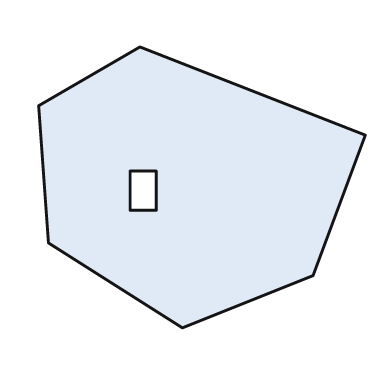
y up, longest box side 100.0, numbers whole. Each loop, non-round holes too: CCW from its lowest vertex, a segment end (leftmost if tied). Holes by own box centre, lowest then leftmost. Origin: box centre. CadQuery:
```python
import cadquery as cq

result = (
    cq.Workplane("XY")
    .moveTo(-6.0, -43.0)
    .lineTo(34.0, -27.0)
    .lineTo(50.0, 16.0)
    .lineTo(-19.0, 43.0)
    .lineTo(-50.0, 25.0)
    .lineTo(-47.0, -17.0)
    .close()
    .moveTo(-22.0, -7.0)
    .lineTo(-14.0, -7.0)
    .lineTo(-14.0, 5.0)
    .lineTo(-22.0, 5.0)
    .close()
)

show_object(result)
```